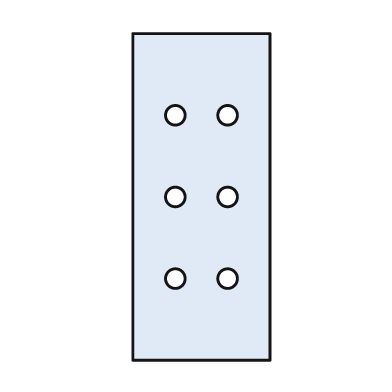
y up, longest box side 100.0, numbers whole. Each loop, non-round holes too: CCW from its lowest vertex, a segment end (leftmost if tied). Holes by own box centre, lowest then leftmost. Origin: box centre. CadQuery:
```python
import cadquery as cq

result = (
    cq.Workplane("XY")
    .moveTo(-21.0, -50.0)
    .lineTo(21.0, -50.0)
    .lineTo(21.0, 50.0)
    .lineTo(-21.0, 50.0)
    .close()
    .moveTo(-8.0, -25.0)
    .circle(3.0)
    .moveTo(8.0, -25.0)
    .circle(3.0)
    .moveTo(-8.0, 0.0)
    .circle(3.0)
    .moveTo(8.0, 0.0)
    .circle(3.0)
    .moveTo(-8.0, 25.0)
    .circle(3.0)
    .moveTo(8.0, 25.0)
    .circle(3.0)
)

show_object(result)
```